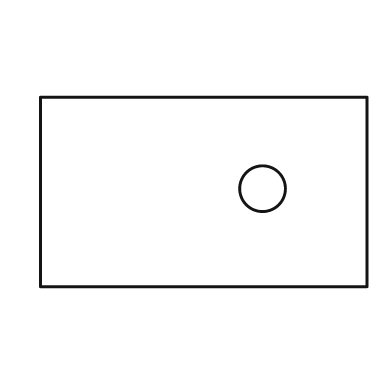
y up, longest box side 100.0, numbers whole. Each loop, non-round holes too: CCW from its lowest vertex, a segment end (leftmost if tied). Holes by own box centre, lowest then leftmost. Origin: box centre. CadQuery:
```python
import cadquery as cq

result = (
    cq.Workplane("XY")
    .moveTo(-50.0, -29.0)
    .lineTo(50.0, -29.0)
    .lineTo(50.0, 29.0)
    .lineTo(-50.0, 29.0)
    .close()
    .moveTo(18.0, 1.0)
    .circle(7.0)
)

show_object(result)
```